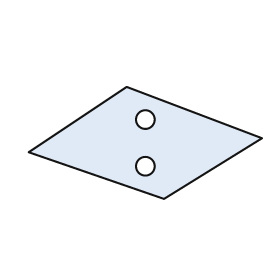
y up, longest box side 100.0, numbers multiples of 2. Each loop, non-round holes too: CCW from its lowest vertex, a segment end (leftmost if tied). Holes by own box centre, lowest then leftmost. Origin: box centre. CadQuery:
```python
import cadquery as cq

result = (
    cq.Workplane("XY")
    .moveTo(8.0, -24.0)
    .lineTo(50.0, 2.0)
    .lineTo(-8.0, 24.0)
    .lineTo(-50.0, -4.0)
    .close()
    .moveTo(0.0, -10.0)
    .circle(4.0)
    .moveTo(0.0, 10.0)
    .circle(4.0)
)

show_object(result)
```